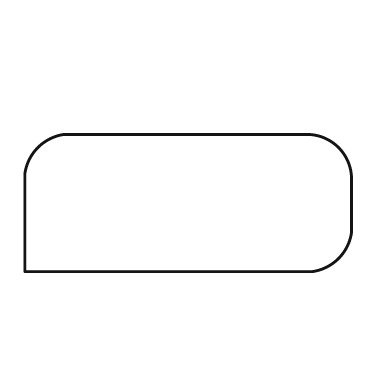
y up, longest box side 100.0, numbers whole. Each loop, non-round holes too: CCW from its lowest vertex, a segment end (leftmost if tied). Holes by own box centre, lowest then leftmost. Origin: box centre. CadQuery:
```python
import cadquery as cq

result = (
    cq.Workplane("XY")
    .moveTo(-50.0, -21.0)
    .lineTo(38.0, -21.0)
    .threePointArc((46.0, -17.0), (50.0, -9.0))
    .lineTo(50.0, 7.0)
    .threePointArc((46.0, 17.0), (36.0, 21.0))
    .lineTo(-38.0, 21.0)
    .threePointArc((-46.0, 17.0), (-50.0, 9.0))
    .close()
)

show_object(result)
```